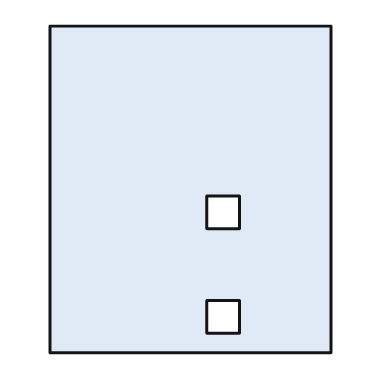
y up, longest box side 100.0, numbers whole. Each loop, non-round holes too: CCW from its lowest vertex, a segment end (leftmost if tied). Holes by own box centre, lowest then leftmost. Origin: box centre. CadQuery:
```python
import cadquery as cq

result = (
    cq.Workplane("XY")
    .moveTo(-43.0, -50.0)
    .lineTo(43.0, -50.0)
    .lineTo(43.0, 50.0)
    .lineTo(-43.0, 50.0)
    .close()
    .moveTo(5.0, -44.0)
    .lineTo(15.0, -44.0)
    .lineTo(15.0, -34.0)
    .lineTo(5.0, -34.0)
    .close()
    .moveTo(5.0, -12.0)
    .lineTo(15.0, -12.0)
    .lineTo(15.0, -2.0)
    .lineTo(5.0, -2.0)
    .close()
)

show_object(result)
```